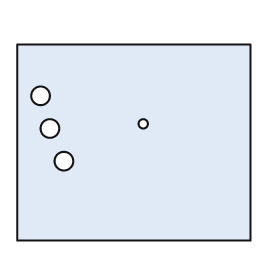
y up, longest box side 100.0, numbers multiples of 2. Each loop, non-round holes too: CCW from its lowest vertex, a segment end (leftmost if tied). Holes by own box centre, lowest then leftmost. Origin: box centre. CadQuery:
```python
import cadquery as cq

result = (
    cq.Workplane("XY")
    .moveTo(-50.0, -42.0)
    .lineTo(50.0, -42.0)
    .lineTo(50.0, 42.0)
    .lineTo(-50.0, 42.0)
    .close()
    .moveTo(-30.0, -8.0)
    .circle(4.0)
    .moveTo(-36.0, 6.0)
    .circle(4.0)
    .moveTo(4.0, 8.0)
    .circle(2.0)
    .moveTo(-40.0, 20.0)
    .circle(4.0)
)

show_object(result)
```